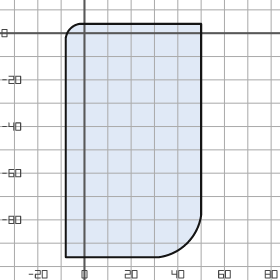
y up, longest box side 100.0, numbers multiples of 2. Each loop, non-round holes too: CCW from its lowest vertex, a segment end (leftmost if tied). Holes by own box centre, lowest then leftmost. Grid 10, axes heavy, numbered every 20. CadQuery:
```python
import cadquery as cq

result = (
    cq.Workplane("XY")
    .moveTo(-8.0, -96.0)
    .lineTo(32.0, -96.0)
    .threePointArc((44.0, -90.0), (50.0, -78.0))
    .lineTo(50.0, 4.0)
    .lineTo(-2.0, 4.0)
    .threePointArc((-6.0, 2.0), (-8.0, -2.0))
    .close()
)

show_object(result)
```